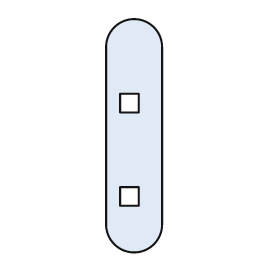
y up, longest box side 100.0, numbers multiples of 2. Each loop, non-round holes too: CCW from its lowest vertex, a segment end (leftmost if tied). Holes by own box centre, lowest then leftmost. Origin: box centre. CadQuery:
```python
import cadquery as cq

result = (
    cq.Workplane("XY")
    .moveTo(-12.0, -38.0)
    .threePointArc((0.0, -50.0), (12.0, -38.0))
    .lineTo(12.0, 38.0)
    .threePointArc((0.0, 50.0), (-12.0, 38.0))
    .close()
    .moveTo(-6.0, -30.0)
    .lineTo(2.0, -30.0)
    .lineTo(2.0, -22.0)
    .lineTo(-6.0, -22.0)
    .close()
    .moveTo(-6.0, 10.0)
    .lineTo(2.0, 10.0)
    .lineTo(2.0, 18.0)
    .lineTo(-6.0, 18.0)
    .close()
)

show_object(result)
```